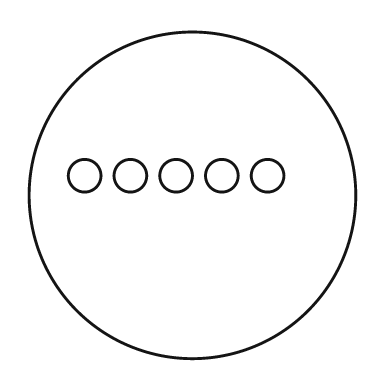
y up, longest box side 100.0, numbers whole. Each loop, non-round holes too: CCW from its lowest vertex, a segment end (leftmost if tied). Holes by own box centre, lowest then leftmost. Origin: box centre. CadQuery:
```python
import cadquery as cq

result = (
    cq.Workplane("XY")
    .moveTo(0.0, 0.0)
    .circle(50.0)
    .moveTo(-33.0, 6.0)
    .circle(5.0)
    .moveTo(-19.0, 6.0)
    .circle(5.0)
    .moveTo(-5.0, 6.0)
    .circle(5.0)
    .moveTo(9.0, 6.0)
    .circle(5.0)
    .moveTo(23.0, 6.0)
    .circle(5.0)
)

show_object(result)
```